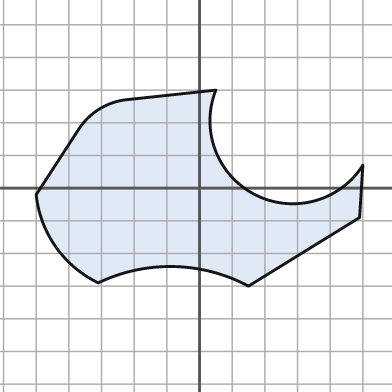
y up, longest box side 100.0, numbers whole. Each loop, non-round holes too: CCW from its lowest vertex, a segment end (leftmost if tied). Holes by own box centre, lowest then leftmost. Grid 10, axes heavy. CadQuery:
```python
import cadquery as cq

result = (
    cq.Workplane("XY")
    .moveTo(15.0, -30.0)
    .lineTo(49.0, -9.0)
    .lineTo(50.0, 7.0)
    .threePointArc((17.0, -2.0), (5.0, 30.0))
    .lineTo(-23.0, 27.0)
    .threePointArc((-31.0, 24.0), (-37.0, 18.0))
    .lineTo(-50.0, -2.0)
    .threePointArc((-44.0, -18.0), (-31.0, -29.0))
    .threePointArc((-8.0, -24.0), (15.0, -30.0))
    .close()
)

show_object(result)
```